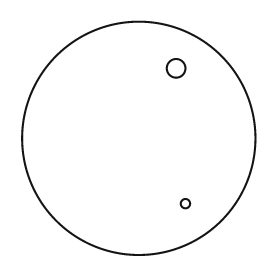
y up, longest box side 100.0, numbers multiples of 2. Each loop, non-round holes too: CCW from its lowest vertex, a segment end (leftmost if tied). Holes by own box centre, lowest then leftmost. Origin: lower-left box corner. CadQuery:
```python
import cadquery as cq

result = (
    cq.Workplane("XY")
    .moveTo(50.0, 50.0)
    .circle(50.0)
    .moveTo(70.0, 22.0)
    .circle(2.0)
    .moveTo(66.0, 80.0)
    .circle(4.0)
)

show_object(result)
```